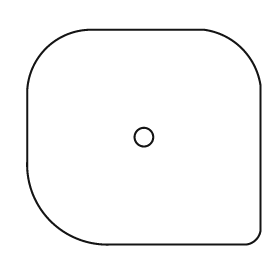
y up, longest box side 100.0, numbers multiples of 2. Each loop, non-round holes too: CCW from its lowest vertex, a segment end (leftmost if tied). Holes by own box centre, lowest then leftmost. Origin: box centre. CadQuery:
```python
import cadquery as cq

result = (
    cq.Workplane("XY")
    .moveTo(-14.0, -46.0)
    .lineTo(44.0, -46.0)
    .threePointArc((48.0, -44.0), (50.0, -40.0))
    .lineTo(50.0, 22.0)
    .threePointArc((42.0, 38.0), (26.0, 46.0))
    .lineTo(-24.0, 46.0)
    .threePointArc((-42.0, 38.0), (-50.0, 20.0))
    .lineTo(-50.0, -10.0)
    .threePointArc((-40.0, -36.0), (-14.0, -46.0))
    .close()
    .moveTo(0.0, 0.0)
    .circle(4.0)
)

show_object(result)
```